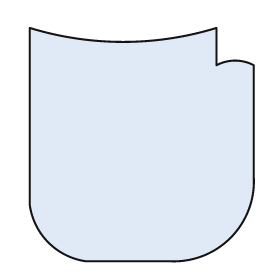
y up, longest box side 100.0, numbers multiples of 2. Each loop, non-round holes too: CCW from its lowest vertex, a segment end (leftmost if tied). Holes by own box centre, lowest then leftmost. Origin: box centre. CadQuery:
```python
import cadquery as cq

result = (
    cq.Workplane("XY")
    .moveTo(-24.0, -50.0)
    .lineTo(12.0, -50.0)
    .threePointArc((38.0, -40.0), (48.0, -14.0))
    .lineTo(48.0, 34.0)
    .threePointArc((40.0, 36.0), (32.0, 34.0))
    .lineTo(32.0, 50.0)
    .threePointArc((-8.0, 44.0), (-48.0, 50.0))
    .lineTo(-48.0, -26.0)
    .threePointArc((-40.0, -42.0), (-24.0, -50.0))
    .close()
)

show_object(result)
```